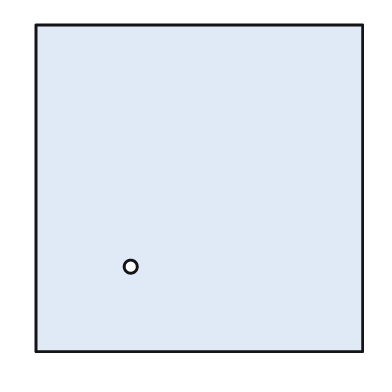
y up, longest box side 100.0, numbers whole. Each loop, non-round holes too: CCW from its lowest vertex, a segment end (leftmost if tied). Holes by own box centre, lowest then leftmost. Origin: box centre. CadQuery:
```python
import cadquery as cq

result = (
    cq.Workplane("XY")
    .moveTo(-50.0, -50.0)
    .lineTo(50.0, -50.0)
    .lineTo(50.0, 50.0)
    .lineTo(-50.0, 50.0)
    .close()
    .moveTo(-21.0, -24.0)
    .circle(2.0)
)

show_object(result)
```